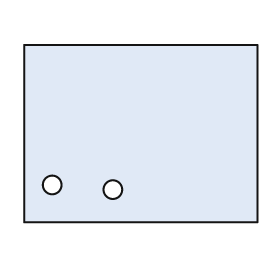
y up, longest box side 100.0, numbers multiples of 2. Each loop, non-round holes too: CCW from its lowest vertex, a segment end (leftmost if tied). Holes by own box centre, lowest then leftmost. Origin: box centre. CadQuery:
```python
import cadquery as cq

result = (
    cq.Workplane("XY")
    .moveTo(-50.0, -38.0)
    .lineTo(50.0, -38.0)
    .lineTo(50.0, 38.0)
    .lineTo(-50.0, 38.0)
    .close()
    .moveTo(-12.0, -24.0)
    .circle(4.0)
    .moveTo(-38.0, -22.0)
    .circle(4.0)
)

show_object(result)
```